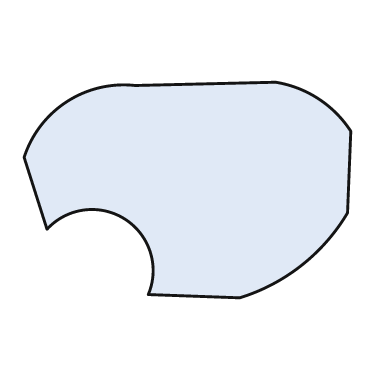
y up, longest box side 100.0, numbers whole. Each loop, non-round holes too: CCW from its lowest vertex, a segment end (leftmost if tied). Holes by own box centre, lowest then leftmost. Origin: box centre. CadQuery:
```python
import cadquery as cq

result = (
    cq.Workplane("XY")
    .moveTo(16.0, -33.0)
    .threePointArc((35.0, -23.0), (49.0, -7.0))
    .lineTo(50.0, 18.0)
    .threePointArc((40.0, 28.0), (27.0, 33.0))
    .lineTo(-16.0, 32.0)
    .threePointArc((-37.0, 27.0), (-50.0, 10.0))
    .lineTo(-43.0, -12.0)
    .threePointArc((-19.0, -9.0), (-12.0, -32.0))
    .close()
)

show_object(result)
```